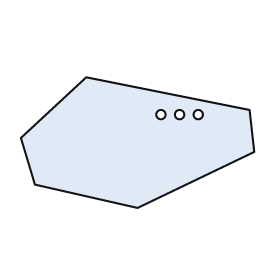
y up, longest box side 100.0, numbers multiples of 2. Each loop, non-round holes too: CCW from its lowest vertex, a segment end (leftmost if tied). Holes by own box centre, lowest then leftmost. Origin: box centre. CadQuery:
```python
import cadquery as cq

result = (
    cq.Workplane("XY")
    .moveTo(0.0, -28.0)
    .lineTo(50.0, -4.0)
    .lineTo(48.0, 14.0)
    .lineTo(-22.0, 28.0)
    .lineTo(-50.0, 2.0)
    .lineTo(-44.0, -18.0)
    .close()
    .moveTo(10.0, 12.0)
    .circle(2.0)
    .moveTo(18.0, 12.0)
    .circle(2.0)
    .moveTo(26.0, 12.0)
    .circle(2.0)
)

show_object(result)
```